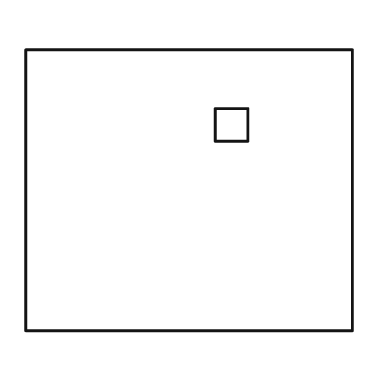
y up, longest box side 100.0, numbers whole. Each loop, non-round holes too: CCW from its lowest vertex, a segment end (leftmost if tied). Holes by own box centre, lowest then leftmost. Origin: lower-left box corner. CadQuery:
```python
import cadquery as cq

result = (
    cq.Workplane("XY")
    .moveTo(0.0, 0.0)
    .lineTo(100.0, 0.0)
    .lineTo(100.0, 86.0)
    .lineTo(0.0, 86.0)
    .close()
    .moveTo(58.0, 58.0)
    .lineTo(68.0, 58.0)
    .lineTo(68.0, 68.0)
    .lineTo(58.0, 68.0)
    .close()
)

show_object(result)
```